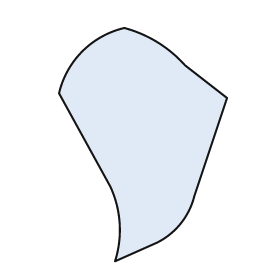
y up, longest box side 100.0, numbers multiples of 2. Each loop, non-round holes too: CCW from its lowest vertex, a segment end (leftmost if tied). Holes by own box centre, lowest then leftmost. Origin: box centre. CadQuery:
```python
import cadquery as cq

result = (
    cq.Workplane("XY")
    .moveTo(-12.0, -50.0)
    .lineTo(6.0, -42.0)
    .threePointArc((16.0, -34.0), (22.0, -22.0))
    .lineTo(36.0, 20.0)
    .lineTo(18.0, 34.0)
    .threePointArc((6.0, 44.0), (-8.0, 50.0))
    .threePointArc((-26.0, 40.0), (-36.0, 22.0))
    .lineTo(-14.0, -18.0)
    .threePointArc((-10.0, -34.0), (-12.0, -50.0))
    .close()
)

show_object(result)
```